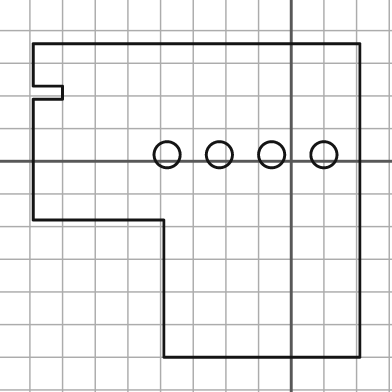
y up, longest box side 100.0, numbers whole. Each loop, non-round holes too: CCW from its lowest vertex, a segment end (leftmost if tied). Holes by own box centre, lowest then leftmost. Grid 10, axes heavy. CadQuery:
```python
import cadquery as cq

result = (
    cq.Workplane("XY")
    .moveTo(-39.0, -60.0)
    .lineTo(21.0, -60.0)
    .lineTo(21.0, 36.0)
    .lineTo(-79.0, 36.0)
    .lineTo(-79.0, 23.0)
    .lineTo(-70.0, 23.0)
    .lineTo(-70.0, 19.0)
    .lineTo(-79.0, 19.0)
    .lineTo(-79.0, -18.0)
    .lineTo(-39.0, -18.0)
    .close()
    .moveTo(-38.0, 2.0)
    .circle(4.0)
    .moveTo(-22.0, 2.0)
    .circle(4.0)
    .moveTo(-6.0, 2.0)
    .circle(4.0)
    .moveTo(10.0, 2.0)
    .circle(4.0)
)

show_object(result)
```